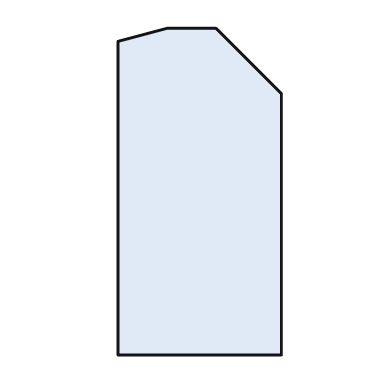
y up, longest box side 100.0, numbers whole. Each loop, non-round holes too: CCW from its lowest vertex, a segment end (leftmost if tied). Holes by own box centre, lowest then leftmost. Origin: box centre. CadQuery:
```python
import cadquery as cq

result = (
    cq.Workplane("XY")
    .moveTo(-25.0, -50.0)
    .lineTo(25.0, -50.0)
    .lineTo(25.0, 30.0)
    .lineTo(5.0, 50.0)
    .lineTo(-10.0, 50.0)
    .lineTo(-25.0, 46.0)
    .close()
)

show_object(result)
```